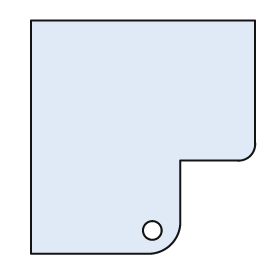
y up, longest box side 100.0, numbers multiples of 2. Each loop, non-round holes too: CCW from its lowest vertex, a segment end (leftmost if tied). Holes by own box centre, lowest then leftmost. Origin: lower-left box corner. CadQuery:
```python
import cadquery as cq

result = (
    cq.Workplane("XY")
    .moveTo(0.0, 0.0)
    .lineTo(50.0, 0.0)
    .threePointArc((60.0, 4.0), (64.0, 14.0))
    .lineTo(64.0, 40.0)
    .lineTo(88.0, 40.0)
    .threePointArc((94.0, 42.0), (96.0, 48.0))
    .lineTo(96.0, 100.0)
    .lineTo(0.0, 100.0)
    .close()
    .moveTo(52.0, 10.0)
    .circle(4.0)
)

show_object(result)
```